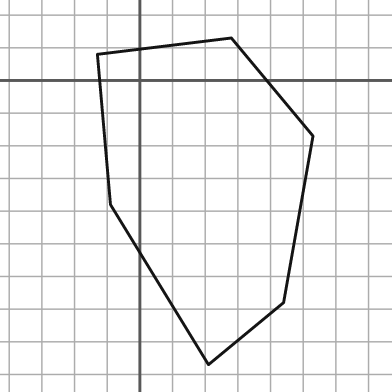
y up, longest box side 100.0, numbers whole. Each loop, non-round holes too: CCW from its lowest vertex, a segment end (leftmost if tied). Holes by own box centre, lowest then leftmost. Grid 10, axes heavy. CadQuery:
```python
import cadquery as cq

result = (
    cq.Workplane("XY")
    .moveTo(21.0, -87.0)
    .lineTo(44.0, -68.0)
    .lineTo(53.0, -17.0)
    .lineTo(28.0, 13.0)
    .lineTo(-13.0, 8.0)
    .lineTo(-9.0, -38.0)
    .close()
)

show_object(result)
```